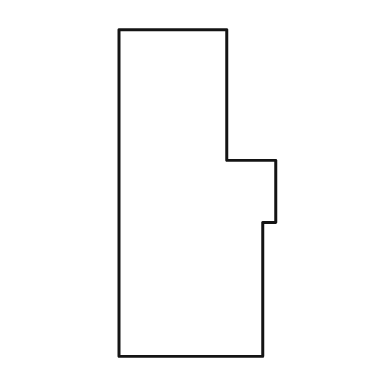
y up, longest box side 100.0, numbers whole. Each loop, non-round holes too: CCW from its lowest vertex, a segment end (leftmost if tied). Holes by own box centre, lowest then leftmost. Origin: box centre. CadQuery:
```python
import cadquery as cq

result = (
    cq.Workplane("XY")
    .moveTo(-24.0, -50.0)
    .lineTo(20.0, -50.0)
    .lineTo(20.0, -9.0)
    .lineTo(24.0, -9.0)
    .lineTo(24.0, 10.0)
    .lineTo(9.0, 10.0)
    .lineTo(9.0, 50.0)
    .lineTo(-24.0, 50.0)
    .close()
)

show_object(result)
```